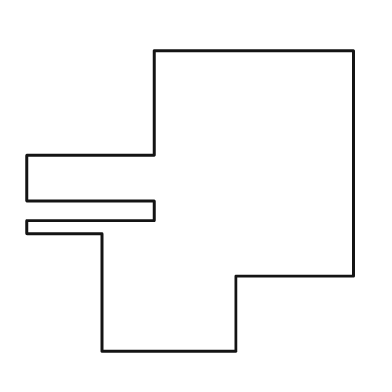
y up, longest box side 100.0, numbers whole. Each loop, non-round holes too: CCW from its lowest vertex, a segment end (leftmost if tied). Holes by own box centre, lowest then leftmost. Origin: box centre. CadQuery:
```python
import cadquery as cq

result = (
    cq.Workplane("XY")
    .moveTo(-27.0, -46.0)
    .lineTo(14.0, -46.0)
    .lineTo(14.0, -23.0)
    .lineTo(50.0, -23.0)
    .lineTo(50.0, 46.0)
    .lineTo(-11.0, 46.0)
    .lineTo(-11.0, 14.0)
    .lineTo(-50.0, 14.0)
    .lineTo(-50.0, 0.0)
    .lineTo(-11.0, 0.0)
    .lineTo(-11.0, -6.0)
    .lineTo(-50.0, -6.0)
    .lineTo(-50.0, -10.0)
    .lineTo(-27.0, -10.0)
    .close()
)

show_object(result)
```